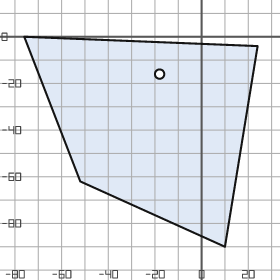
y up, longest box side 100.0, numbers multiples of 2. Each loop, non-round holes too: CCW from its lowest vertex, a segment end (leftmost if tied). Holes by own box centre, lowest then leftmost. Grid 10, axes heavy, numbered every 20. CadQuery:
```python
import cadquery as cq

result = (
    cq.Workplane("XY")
    .moveTo(10.0, -90.0)
    .lineTo(24.0, -4.0)
    .lineTo(-76.0, 0.0)
    .lineTo(-52.0, -62.0)
    .close()
    .moveTo(-18.0, -16.0)
    .circle(2.0)
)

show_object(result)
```